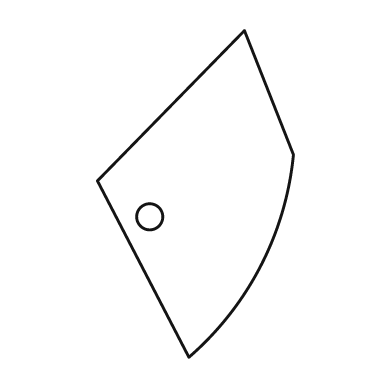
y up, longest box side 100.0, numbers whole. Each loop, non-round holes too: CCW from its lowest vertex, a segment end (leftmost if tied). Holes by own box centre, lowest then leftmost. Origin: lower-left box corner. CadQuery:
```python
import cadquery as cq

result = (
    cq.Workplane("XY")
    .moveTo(28.0, 0.0)
    .threePointArc((50.0, 28.0), (60.0, 62.0))
    .lineTo(45.0, 100.0)
    .lineTo(0.0, 54.0)
    .close()
    .moveTo(16.0, 43.0)
    .circle(4.0)
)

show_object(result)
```